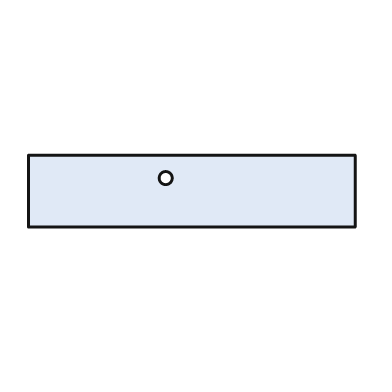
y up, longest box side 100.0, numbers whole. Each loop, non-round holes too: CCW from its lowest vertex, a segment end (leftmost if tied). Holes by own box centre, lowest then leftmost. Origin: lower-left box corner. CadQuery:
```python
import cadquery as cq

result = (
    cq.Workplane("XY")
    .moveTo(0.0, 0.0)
    .lineTo(100.0, 0.0)
    .lineTo(100.0, 22.0)
    .lineTo(0.0, 22.0)
    .close()
    .moveTo(42.0, 15.0)
    .circle(2.0)
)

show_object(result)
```